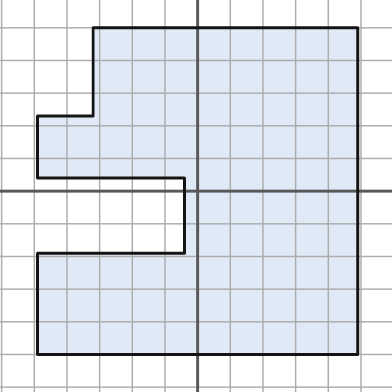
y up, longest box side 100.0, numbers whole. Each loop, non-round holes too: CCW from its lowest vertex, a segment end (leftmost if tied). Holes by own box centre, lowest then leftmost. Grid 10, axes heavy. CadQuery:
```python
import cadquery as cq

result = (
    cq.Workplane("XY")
    .moveTo(-49.0, -50.0)
    .lineTo(49.0, -50.0)
    .lineTo(49.0, 50.0)
    .lineTo(-32.0, 50.0)
    .lineTo(-32.0, 23.0)
    .lineTo(-49.0, 23.0)
    .lineTo(-49.0, 4.0)
    .lineTo(-4.0, 4.0)
    .lineTo(-4.0, -19.0)
    .lineTo(-49.0, -19.0)
    .close()
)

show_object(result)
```